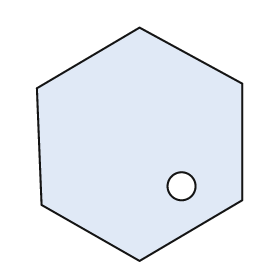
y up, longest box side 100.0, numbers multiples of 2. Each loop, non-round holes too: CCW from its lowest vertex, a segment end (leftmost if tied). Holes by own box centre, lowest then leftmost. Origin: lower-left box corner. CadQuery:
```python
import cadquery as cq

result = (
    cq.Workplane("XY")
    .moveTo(44.0, 0.0)
    .lineTo(88.0, 26.0)
    .lineTo(88.0, 76.0)
    .lineTo(44.0, 100.0)
    .lineTo(0.0, 74.0)
    .lineTo(2.0, 24.0)
    .close()
    .moveTo(62.0, 32.0)
    .circle(6.0)
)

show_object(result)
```